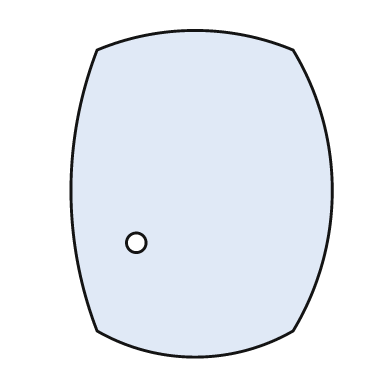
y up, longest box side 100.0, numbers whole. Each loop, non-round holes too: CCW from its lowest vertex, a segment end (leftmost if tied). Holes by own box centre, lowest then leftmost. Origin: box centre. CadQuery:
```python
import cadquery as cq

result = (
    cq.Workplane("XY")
    .moveTo(-32.0, -42.0)
    .threePointArc((-2.0, -50.0), (28.0, -42.0))
    .threePointArc((40.0, 1.0), (28.0, 44.0))
    .threePointArc((-2.0, 50.0), (-32.0, 44.0))
    .threePointArc((-40.0, 1.0), (-32.0, -42.0))
    .close()
    .moveTo(-20.0, -15.0)
    .circle(3.0)
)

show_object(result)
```